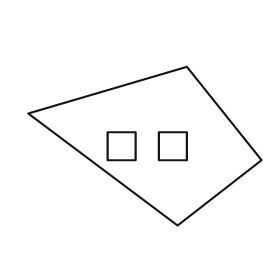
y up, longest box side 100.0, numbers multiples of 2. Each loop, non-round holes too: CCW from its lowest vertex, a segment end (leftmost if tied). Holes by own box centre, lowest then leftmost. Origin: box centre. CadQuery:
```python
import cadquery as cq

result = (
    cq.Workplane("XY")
    .moveTo(14.0, -34.0)
    .lineTo(50.0, -6.0)
    .lineTo(18.0, 34.0)
    .lineTo(-50.0, 14.0)
    .close()
    .moveTo(-16.0, -6.0)
    .lineTo(-4.0, -6.0)
    .lineTo(-4.0, 6.0)
    .lineTo(-16.0, 6.0)
    .close()
    .moveTo(6.0, -6.0)
    .lineTo(18.0, -6.0)
    .lineTo(18.0, 6.0)
    .lineTo(6.0, 6.0)
    .close()
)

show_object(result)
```